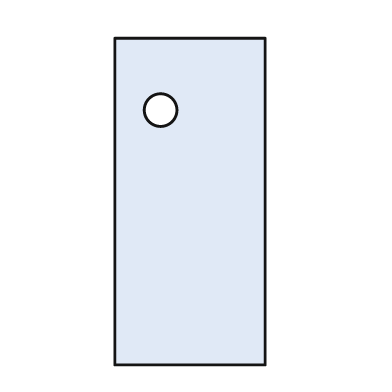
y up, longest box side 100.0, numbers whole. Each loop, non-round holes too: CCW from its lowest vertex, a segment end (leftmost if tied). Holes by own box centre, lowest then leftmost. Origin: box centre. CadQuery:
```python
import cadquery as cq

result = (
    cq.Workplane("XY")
    .moveTo(-23.0, -50.0)
    .lineTo(23.0, -50.0)
    .lineTo(23.0, 50.0)
    .lineTo(-23.0, 50.0)
    .close()
    .moveTo(-9.0, 28.0)
    .circle(5.0)
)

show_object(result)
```